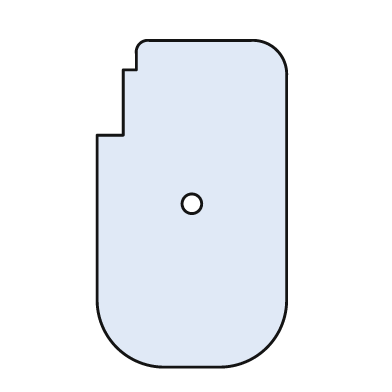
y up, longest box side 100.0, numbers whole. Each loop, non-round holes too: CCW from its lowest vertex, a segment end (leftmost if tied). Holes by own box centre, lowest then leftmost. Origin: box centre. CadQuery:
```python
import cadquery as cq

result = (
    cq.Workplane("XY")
    .moveTo(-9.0, -50.0)
    .lineTo(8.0, -50.0)
    .threePointArc((23.0, -44.0), (29.0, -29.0))
    .lineTo(29.0, 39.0)
    .threePointArc((26.0, 47.0), (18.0, 50.0))
    .lineTo(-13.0, 50.0)
    .threePointArc((-16.0, 49.0), (-17.0, 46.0))
    .lineTo(-17.0, 41.0)
    .lineTo(-21.0, 41.0)
    .lineTo(-21.0, 21.0)
    .lineTo(-29.0, 21.0)
    .lineTo(-29.0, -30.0)
    .threePointArc((-23.0, -44.0), (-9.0, -50.0))
    .close()
    .moveTo(0.0, 0.0)
    .circle(3.0)
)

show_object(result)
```